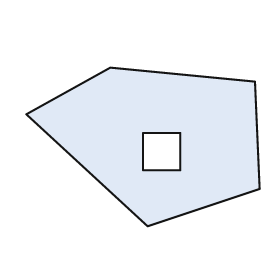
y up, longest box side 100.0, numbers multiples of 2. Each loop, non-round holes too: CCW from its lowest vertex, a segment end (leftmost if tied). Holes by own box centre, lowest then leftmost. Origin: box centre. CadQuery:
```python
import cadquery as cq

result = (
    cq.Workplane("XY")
    .moveTo(2.0, -34.0)
    .lineTo(50.0, -18.0)
    .lineTo(48.0, 28.0)
    .lineTo(-14.0, 34.0)
    .lineTo(-50.0, 14.0)
    .close()
    .moveTo(0.0, -10.0)
    .lineTo(16.0, -10.0)
    .lineTo(16.0, 6.0)
    .lineTo(0.0, 6.0)
    .close()
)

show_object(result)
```